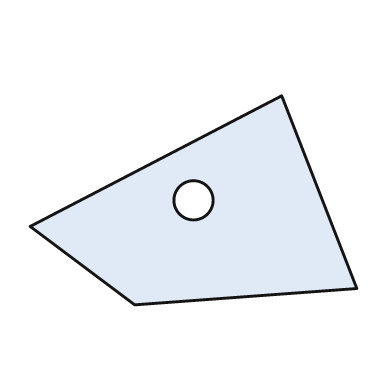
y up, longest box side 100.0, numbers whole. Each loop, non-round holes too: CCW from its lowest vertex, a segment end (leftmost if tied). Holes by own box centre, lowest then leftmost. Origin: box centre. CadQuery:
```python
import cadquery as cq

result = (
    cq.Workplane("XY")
    .moveTo(-18.0, -32.0)
    .lineTo(50.0, -27.0)
    .lineTo(27.0, 32.0)
    .lineTo(-50.0, -8.0)
    .close()
    .moveTo(0.0, 0.0)
    .circle(6.0)
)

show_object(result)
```